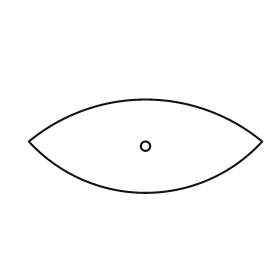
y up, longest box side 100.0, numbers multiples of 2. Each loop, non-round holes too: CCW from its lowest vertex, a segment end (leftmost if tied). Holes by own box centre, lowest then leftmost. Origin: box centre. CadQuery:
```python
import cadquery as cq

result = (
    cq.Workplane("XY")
    .moveTo(-50.0, 2.0)
    .threePointArc((0.0, -20.0), (50.0, 2.0))
    .threePointArc((0.0, 20.0), (-50.0, 2.0))
    .close()
    .moveTo(0.0, 0.0)
    .circle(2.0)
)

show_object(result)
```